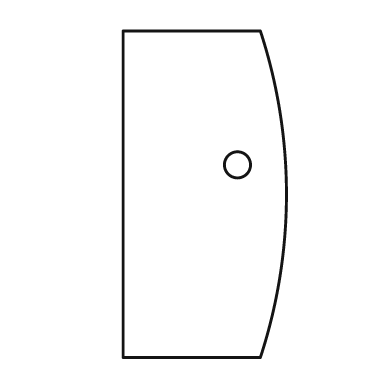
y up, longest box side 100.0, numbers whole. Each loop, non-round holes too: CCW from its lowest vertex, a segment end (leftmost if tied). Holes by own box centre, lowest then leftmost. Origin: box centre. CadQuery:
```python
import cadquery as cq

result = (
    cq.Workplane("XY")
    .moveTo(-25.0, -50.0)
    .lineTo(17.0, -50.0)
    .threePointArc((25.0, 0.0), (17.0, 50.0))
    .lineTo(-25.0, 50.0)
    .close()
    .moveTo(10.0, 9.0)
    .circle(4.0)
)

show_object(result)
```